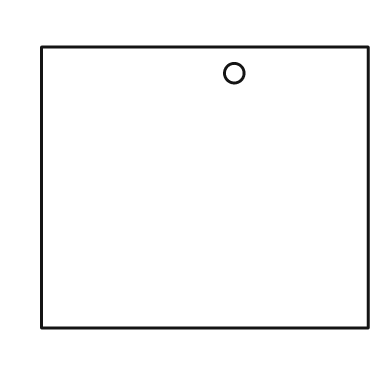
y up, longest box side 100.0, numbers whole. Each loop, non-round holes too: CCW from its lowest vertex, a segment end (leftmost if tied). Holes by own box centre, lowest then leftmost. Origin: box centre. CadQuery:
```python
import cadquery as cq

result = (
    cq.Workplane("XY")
    .moveTo(-50.0, -43.0)
    .lineTo(50.0, -43.0)
    .lineTo(50.0, 43.0)
    .lineTo(-50.0, 43.0)
    .close()
    .moveTo(9.0, 35.0)
    .circle(3.0)
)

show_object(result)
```